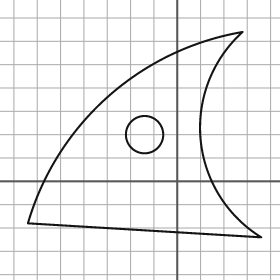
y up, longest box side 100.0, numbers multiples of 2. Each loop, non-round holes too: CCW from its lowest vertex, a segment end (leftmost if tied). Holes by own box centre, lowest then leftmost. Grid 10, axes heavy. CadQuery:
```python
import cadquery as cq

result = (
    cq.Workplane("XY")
    .moveTo(36.0, -24.0)
    .threePointArc((10.0, 18.0), (28.0, 64.0))
    .threePointArc((-30.0, 36.0), (-64.0, -18.0))
    .close()
    .moveTo(-14.0, 20.0)
    .circle(8.0)
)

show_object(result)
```